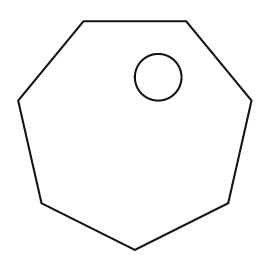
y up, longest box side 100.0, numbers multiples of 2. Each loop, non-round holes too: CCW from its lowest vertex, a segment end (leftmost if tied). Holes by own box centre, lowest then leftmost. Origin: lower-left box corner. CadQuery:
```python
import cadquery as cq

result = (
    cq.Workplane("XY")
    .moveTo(50.0, 0.0)
    .lineTo(90.0, 20.0)
    .lineTo(100.0, 64.0)
    .lineTo(72.0, 98.0)
    .lineTo(28.0, 98.0)
    .lineTo(0.0, 64.0)
    .lineTo(10.0, 20.0)
    .close()
    .moveTo(60.0, 74.0)
    .circle(10.0)
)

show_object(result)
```